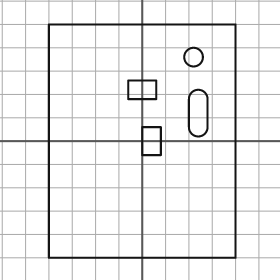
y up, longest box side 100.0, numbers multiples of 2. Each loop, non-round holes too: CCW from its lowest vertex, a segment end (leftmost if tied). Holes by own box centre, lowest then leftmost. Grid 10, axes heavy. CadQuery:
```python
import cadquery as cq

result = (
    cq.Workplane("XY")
    .moveTo(-40.0, -50.0)
    .lineTo(40.0, -50.0)
    .lineTo(40.0, 50.0)
    .lineTo(-40.0, 50.0)
    .close()
    .moveTo(0.0, -6.0)
    .lineTo(8.0, -6.0)
    .lineTo(8.0, 6.0)
    .lineTo(0.0, 6.0)
    .close()
    .moveTo(20.0, 6.0)
    .threePointArc((24.0, 2.0), (28.0, 6.0))
    .lineTo(28.0, 18.0)
    .threePointArc((24.0, 22.0), (20.0, 18.0))
    .close()
    .moveTo(-6.0, 18.0)
    .lineTo(6.0, 18.0)
    .lineTo(6.0, 26.0)
    .lineTo(-6.0, 26.0)
    .close()
    .moveTo(22.0, 36.0)
    .circle(4.0)
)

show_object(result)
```